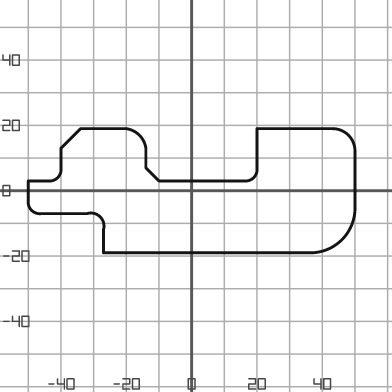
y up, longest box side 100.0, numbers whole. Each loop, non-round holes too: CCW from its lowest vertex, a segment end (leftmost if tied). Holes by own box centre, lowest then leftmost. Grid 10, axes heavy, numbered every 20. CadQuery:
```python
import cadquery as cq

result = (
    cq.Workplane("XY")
    .moveTo(-27.0, -19.0)
    .lineTo(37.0, -19.0)
    .threePointArc((46.0, -15.0), (50.0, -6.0))
    .lineTo(50.0, 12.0)
    .threePointArc((48.0, 17.0), (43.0, 19.0))
    .lineTo(20.0, 19.0)
    .lineTo(20.0, 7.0)
    .threePointArc((19.0, 4.0), (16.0, 3.0))
    .lineTo(-10.0, 3.0)
    .lineTo(-14.0, 7.0)
    .lineTo(-14.0, 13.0)
    .threePointArc((-16.0, 17.0), (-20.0, 19.0))
    .lineTo(-34.0, 19.0)
    .lineTo(-40.0, 13.0)
    .lineTo(-40.0, 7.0)
    .threePointArc((-41.0, 4.0), (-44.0, 3.0))
    .lineTo(-50.0, 3.0)
    .lineTo(-50.0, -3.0)
    .threePointArc((-49.0, -6.0), (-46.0, -7.0))
    .lineTo(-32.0, -7.0)
    .threePointArc((-28.0, -8.0), (-27.0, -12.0))
    .close()
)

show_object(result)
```